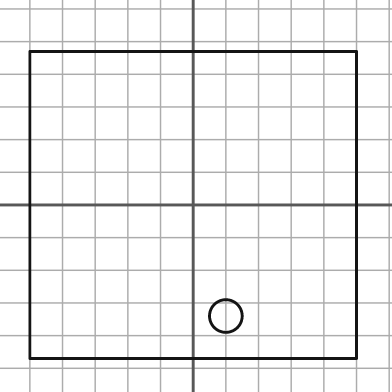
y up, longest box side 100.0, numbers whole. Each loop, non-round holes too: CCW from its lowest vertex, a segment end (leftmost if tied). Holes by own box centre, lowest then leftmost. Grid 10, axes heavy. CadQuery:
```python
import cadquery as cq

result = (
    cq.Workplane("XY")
    .moveTo(-50.0, -47.0)
    .lineTo(50.0, -47.0)
    .lineTo(50.0, 47.0)
    .lineTo(-50.0, 47.0)
    .close()
    .moveTo(10.0, -34.0)
    .circle(5.0)
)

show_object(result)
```